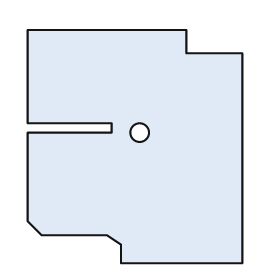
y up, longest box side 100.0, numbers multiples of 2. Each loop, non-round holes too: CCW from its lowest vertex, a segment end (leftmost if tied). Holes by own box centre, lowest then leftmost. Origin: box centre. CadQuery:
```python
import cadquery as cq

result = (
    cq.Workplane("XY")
    .moveTo(-6.0, -50.0)
    .lineTo(46.0, -50.0)
    .lineTo(46.0, 40.0)
    .lineTo(22.0, 40.0)
    .lineTo(22.0, 50.0)
    .lineTo(-46.0, 50.0)
    .lineTo(-46.0, 10.0)
    .lineTo(-10.0, 10.0)
    .lineTo(-10.0, 6.0)
    .lineTo(-46.0, 6.0)
    .lineTo(-46.0, -32.0)
    .lineTo(-40.0, -38.0)
    .lineTo(-12.0, -38.0)
    .lineTo(-6.0, -42.0)
    .close()
    .moveTo(2.0, 6.0)
    .circle(4.0)
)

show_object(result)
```